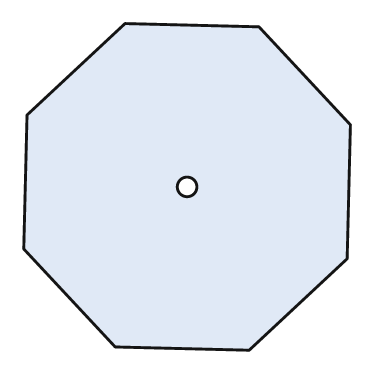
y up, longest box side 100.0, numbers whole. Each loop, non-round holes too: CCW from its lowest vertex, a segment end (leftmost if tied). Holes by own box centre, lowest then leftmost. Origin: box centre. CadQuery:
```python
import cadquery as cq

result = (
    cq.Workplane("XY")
    .moveTo(19.0, -50.0)
    .lineTo(49.0, -22.0)
    .lineTo(50.0, 19.0)
    .lineTo(22.0, 49.0)
    .lineTo(-19.0, 50.0)
    .lineTo(-49.0, 22.0)
    .lineTo(-50.0, -19.0)
    .lineTo(-22.0, -49.0)
    .close()
    .moveTo(0.0, 0.0)
    .circle(3.0)
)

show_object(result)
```